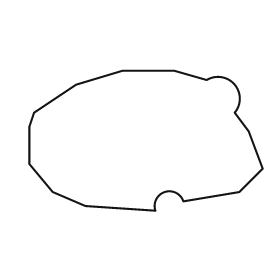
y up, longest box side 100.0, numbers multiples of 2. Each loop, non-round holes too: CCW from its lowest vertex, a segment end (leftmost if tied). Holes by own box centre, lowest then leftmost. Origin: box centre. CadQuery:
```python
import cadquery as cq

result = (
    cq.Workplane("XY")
    .moveTo(4.0, -30.0)
    .threePointArc((8.0, -22.0), (16.0, -26.0))
    .lineTo(40.0, -22.0)
    .lineTo(50.0, -12.0)
    .lineTo(44.0, 4.0)
    .lineTo(38.0, 12.0)
    .threePointArc((38.0, 24.0), (26.0, 26.0))
    .lineTo(12.0, 30.0)
    .lineTo(-10.0, 30.0)
    .lineTo(-30.0, 24.0)
    .lineTo(-48.0, 12.0)
    .lineTo(-50.0, 6.0)
    .lineTo(-50.0, -10.0)
    .lineTo(-40.0, -22.0)
    .lineTo(-26.0, -28.0)
    .close()
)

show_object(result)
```